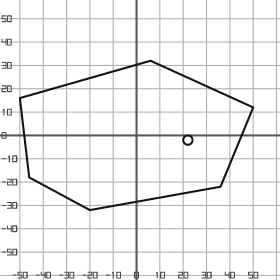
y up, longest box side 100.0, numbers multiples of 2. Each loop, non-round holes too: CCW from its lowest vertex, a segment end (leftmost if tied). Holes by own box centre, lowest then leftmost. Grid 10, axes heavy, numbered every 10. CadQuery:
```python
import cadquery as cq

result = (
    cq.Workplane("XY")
    .moveTo(-20.0, -32.0)
    .lineTo(36.0, -22.0)
    .lineTo(50.0, 12.0)
    .lineTo(6.0, 32.0)
    .lineTo(-50.0, 16.0)
    .lineTo(-46.0, -18.0)
    .close()
    .moveTo(22.0, -2.0)
    .circle(2.0)
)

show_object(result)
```